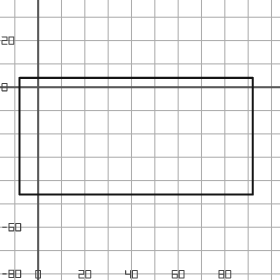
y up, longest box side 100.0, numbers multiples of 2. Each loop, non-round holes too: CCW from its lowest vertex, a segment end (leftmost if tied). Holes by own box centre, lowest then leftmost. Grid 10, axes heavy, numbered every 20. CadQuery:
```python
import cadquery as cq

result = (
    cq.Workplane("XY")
    .moveTo(-8.0, -46.0)
    .lineTo(92.0, -46.0)
    .lineTo(92.0, 4.0)
    .lineTo(-8.0, 4.0)
    .close()
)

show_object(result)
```